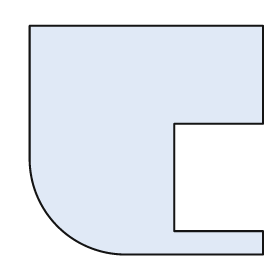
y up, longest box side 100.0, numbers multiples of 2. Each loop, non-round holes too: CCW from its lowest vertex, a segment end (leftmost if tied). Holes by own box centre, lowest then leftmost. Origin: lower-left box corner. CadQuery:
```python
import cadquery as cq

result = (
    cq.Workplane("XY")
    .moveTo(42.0, 0.0)
    .lineTo(100.0, 0.0)
    .lineTo(100.0, 10.0)
    .lineTo(62.0, 10.0)
    .lineTo(62.0, 56.0)
    .lineTo(100.0, 56.0)
    .lineTo(100.0, 98.0)
    .lineTo(0.0, 98.0)
    .lineTo(0.0, 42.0)
    .threePointArc((12.0, 12.0), (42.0, 0.0))
    .close()
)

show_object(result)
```